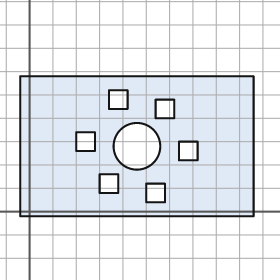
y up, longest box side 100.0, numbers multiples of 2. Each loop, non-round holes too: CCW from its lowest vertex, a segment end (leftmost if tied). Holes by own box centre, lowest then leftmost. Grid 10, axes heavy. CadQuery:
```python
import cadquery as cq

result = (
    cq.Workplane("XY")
    .moveTo(-4.0, -2.0)
    .lineTo(96.0, -2.0)
    .lineTo(96.0, 58.0)
    .lineTo(-4.0, 58.0)
    .close()
    .moveTo(50.0, 4.0)
    .lineTo(58.0, 4.0)
    .lineTo(58.0, 12.0)
    .lineTo(50.0, 12.0)
    .close()
    .moveTo(30.0, 8.0)
    .lineTo(38.0, 8.0)
    .lineTo(38.0, 16.0)
    .lineTo(30.0, 16.0)
    .close()
    .moveTo(64.0, 22.0)
    .lineTo(72.0, 22.0)
    .lineTo(72.0, 30.0)
    .lineTo(64.0, 30.0)
    .close()
    .moveTo(46.0, 28.0)
    .circle(10.0)
    .moveTo(20.0, 26.0)
    .lineTo(28.0, 26.0)
    .lineTo(28.0, 34.0)
    .lineTo(20.0, 34.0)
    .close()
    .moveTo(54.0, 40.0)
    .lineTo(62.0, 40.0)
    .lineTo(62.0, 48.0)
    .lineTo(54.0, 48.0)
    .close()
    .moveTo(34.0, 44.0)
    .lineTo(42.0, 44.0)
    .lineTo(42.0, 52.0)
    .lineTo(34.0, 52.0)
    .close()
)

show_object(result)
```